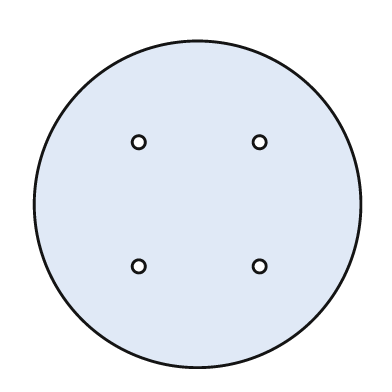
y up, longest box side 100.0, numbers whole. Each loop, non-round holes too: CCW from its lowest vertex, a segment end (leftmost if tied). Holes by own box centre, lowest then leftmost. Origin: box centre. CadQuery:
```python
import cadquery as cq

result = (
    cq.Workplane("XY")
    .moveTo(0.0, 0.0)
    .circle(50.0)
    .moveTo(-18.0, -19.0)
    .circle(2.0)
    .moveTo(19.0, -19.0)
    .circle(2.0)
    .moveTo(-18.0, 19.0)
    .circle(2.0)
    .moveTo(19.0, 19.0)
    .circle(2.0)
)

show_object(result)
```